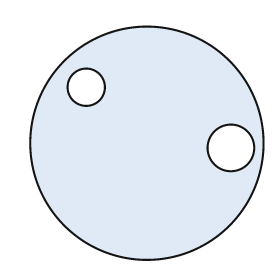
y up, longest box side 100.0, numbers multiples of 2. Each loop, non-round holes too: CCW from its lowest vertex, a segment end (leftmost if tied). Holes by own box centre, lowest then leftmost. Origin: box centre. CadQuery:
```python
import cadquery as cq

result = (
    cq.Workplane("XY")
    .moveTo(0.0, 0.0)
    .circle(50.0)
    .moveTo(36.0, -2.0)
    .circle(10.0)
    .moveTo(-26.0, 24.0)
    .circle(8.0)
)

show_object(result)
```